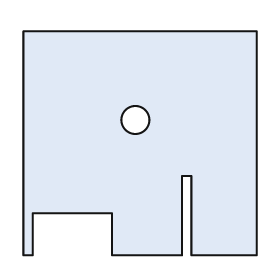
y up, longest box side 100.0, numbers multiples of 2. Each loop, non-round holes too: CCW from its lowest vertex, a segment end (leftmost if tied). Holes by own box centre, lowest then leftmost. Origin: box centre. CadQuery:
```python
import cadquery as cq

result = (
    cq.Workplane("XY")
    .moveTo(-50.0, -48.0)
    .lineTo(-46.0, -48.0)
    .lineTo(-46.0, -30.0)
    .lineTo(-12.0, -30.0)
    .lineTo(-12.0, -48.0)
    .lineTo(18.0, -48.0)
    .lineTo(18.0, -14.0)
    .lineTo(22.0, -14.0)
    .lineTo(22.0, -48.0)
    .lineTo(50.0, -48.0)
    .lineTo(50.0, 48.0)
    .lineTo(-50.0, 48.0)
    .close()
    .moveTo(-2.0, 10.0)
    .circle(6.0)
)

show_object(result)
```